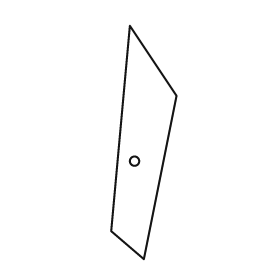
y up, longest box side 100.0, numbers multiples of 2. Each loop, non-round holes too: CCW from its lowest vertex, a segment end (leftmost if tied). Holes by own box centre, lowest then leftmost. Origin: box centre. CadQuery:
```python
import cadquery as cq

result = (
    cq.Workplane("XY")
    .moveTo(0.0, -50.0)
    .lineTo(14.0, 20.0)
    .lineTo(-6.0, 50.0)
    .lineTo(-14.0, -38.0)
    .close()
    .moveTo(-4.0, -8.0)
    .circle(2.0)
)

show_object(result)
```